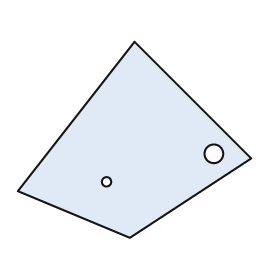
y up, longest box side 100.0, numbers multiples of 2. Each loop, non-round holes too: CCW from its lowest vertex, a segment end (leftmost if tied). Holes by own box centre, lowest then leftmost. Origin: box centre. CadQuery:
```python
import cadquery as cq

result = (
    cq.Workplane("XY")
    .moveTo(-2.0, -42.0)
    .lineTo(50.0, -8.0)
    .lineTo(0.0, 42.0)
    .lineTo(-50.0, -22.0)
    .close()
    .moveTo(-12.0, -18.0)
    .circle(2.0)
    .moveTo(34.0, -6.0)
    .circle(4.0)
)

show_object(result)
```